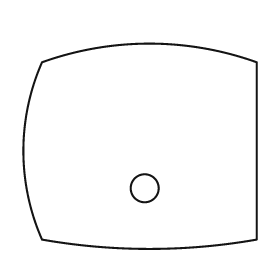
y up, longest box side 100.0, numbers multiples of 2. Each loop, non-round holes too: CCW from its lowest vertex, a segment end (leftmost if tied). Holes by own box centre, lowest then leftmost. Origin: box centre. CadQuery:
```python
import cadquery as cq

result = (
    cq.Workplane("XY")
    .moveTo(-42.0, -40.0)
    .threePointArc((4.0, -44.0), (50.0, -40.0))
    .lineTo(50.0, 36.0)
    .threePointArc((4.0, 44.0), (-42.0, 36.0))
    .threePointArc((-50.0, -2.0), (-42.0, -40.0))
    .close()
    .moveTo(2.0, -18.0)
    .circle(6.0)
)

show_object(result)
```